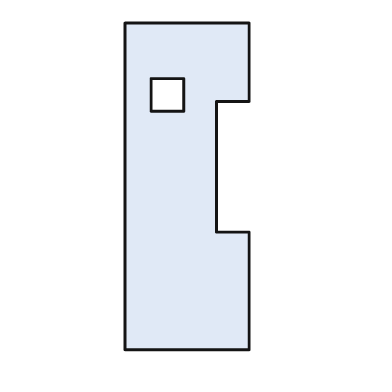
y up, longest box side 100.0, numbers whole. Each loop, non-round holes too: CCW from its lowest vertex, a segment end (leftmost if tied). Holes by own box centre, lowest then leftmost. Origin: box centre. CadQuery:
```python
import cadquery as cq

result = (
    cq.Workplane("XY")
    .moveTo(-19.0, -50.0)
    .lineTo(19.0, -50.0)
    .lineTo(19.0, -14.0)
    .lineTo(9.0, -14.0)
    .lineTo(9.0, 26.0)
    .lineTo(19.0, 26.0)
    .lineTo(19.0, 50.0)
    .lineTo(-19.0, 50.0)
    .close()
    .moveTo(-11.0, 23.0)
    .lineTo(-1.0, 23.0)
    .lineTo(-1.0, 33.0)
    .lineTo(-11.0, 33.0)
    .close()
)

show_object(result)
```